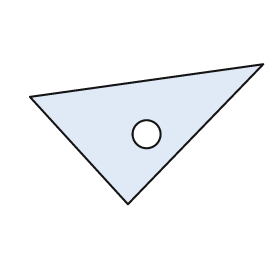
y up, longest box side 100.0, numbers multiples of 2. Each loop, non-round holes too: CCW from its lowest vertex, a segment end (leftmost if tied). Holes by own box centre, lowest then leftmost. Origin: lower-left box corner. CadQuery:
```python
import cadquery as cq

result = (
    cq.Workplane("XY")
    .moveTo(42.0, 0.0)
    .lineTo(100.0, 60.0)
    .lineTo(0.0, 46.0)
    .close()
    .moveTo(50.0, 30.0)
    .circle(6.0)
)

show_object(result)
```